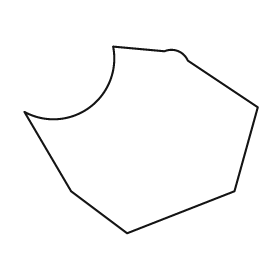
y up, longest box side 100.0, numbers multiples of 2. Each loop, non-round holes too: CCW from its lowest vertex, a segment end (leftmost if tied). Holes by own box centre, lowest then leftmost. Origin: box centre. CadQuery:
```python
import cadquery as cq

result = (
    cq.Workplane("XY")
    .moveTo(-6.0, -40.0)
    .lineTo(40.0, -22.0)
    .lineTo(50.0, 14.0)
    .lineTo(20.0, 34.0)
    .threePointArc((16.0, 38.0), (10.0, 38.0))
    .lineTo(-12.0, 40.0)
    .threePointArc((-22.0, 14.0), (-50.0, 12.0))
    .lineTo(-30.0, -22.0)
    .close()
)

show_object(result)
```